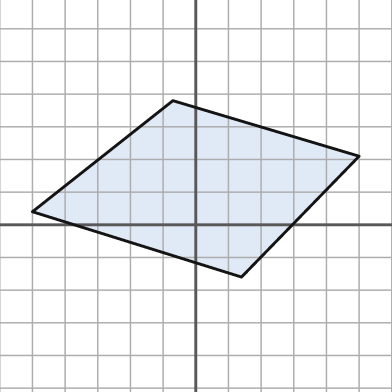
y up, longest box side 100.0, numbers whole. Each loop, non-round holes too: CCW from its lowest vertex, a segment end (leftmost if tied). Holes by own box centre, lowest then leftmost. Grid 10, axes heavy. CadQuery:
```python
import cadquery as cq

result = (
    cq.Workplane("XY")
    .moveTo(14.0, -16.0)
    .lineTo(50.0, 21.0)
    .lineTo(-7.0, 38.0)
    .lineTo(-50.0, 4.0)
    .close()
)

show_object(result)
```